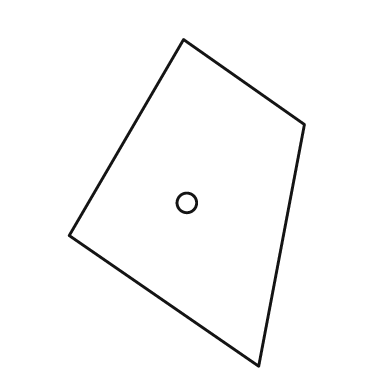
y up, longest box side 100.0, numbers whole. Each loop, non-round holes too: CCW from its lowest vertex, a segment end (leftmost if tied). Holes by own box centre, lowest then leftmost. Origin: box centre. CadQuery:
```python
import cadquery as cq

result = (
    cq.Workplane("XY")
    .moveTo(22.0, -50.0)
    .lineTo(36.0, 24.0)
    .lineTo(-1.0, 50.0)
    .lineTo(-36.0, -10.0)
    .close()
    .moveTo(0.0, 0.0)
    .circle(3.0)
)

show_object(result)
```